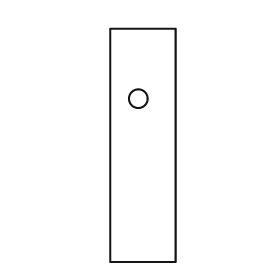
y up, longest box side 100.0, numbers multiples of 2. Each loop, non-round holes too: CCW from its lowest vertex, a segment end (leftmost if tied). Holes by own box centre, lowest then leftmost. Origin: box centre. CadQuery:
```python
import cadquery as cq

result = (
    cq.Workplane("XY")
    .moveTo(-14.0, -50.0)
    .lineTo(14.0, -50.0)
    .lineTo(14.0, 50.0)
    .lineTo(-14.0, 50.0)
    .close()
    .moveTo(-2.0, 20.0)
    .circle(4.0)
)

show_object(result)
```